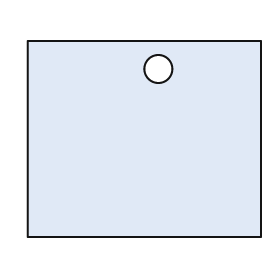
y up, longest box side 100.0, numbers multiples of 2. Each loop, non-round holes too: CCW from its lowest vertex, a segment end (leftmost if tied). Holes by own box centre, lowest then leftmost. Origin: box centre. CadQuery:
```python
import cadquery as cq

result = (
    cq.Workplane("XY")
    .moveTo(-50.0, -42.0)
    .lineTo(50.0, -42.0)
    .lineTo(50.0, 42.0)
    .lineTo(-50.0, 42.0)
    .close()
    .moveTo(6.0, 30.0)
    .circle(6.0)
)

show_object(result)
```